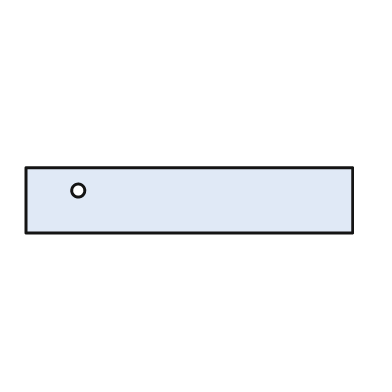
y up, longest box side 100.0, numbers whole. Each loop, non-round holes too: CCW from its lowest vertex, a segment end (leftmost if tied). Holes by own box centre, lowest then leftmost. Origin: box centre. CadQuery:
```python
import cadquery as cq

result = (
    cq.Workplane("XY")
    .moveTo(-50.0, -10.0)
    .lineTo(50.0, -10.0)
    .lineTo(50.0, 10.0)
    .lineTo(-50.0, 10.0)
    .close()
    .moveTo(-34.0, 3.0)
    .circle(2.0)
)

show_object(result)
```